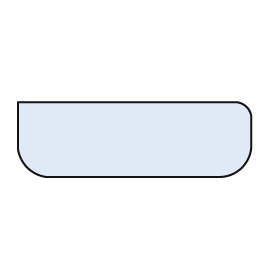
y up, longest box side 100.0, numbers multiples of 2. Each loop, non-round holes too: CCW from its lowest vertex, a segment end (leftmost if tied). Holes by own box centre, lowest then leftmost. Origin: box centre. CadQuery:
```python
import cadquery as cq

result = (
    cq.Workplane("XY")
    .moveTo(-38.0, -16.0)
    .lineTo(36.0, -16.0)
    .threePointArc((46.0, -12.0), (50.0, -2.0))
    .lineTo(50.0, 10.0)
    .threePointArc((48.0, 14.0), (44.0, 16.0))
    .lineTo(-50.0, 16.0)
    .lineTo(-50.0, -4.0)
    .threePointArc((-46.0, -12.0), (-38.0, -16.0))
    .close()
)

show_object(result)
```